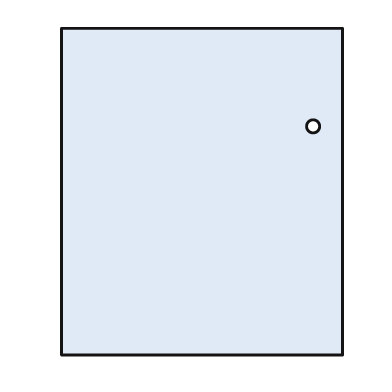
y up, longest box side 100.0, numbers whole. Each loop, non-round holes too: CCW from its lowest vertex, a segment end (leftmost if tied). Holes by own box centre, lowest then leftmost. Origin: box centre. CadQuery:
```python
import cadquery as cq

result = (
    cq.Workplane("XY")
    .moveTo(-43.0, -50.0)
    .lineTo(43.0, -50.0)
    .lineTo(43.0, 50.0)
    .lineTo(-43.0, 50.0)
    .close()
    .moveTo(34.0, 20.0)
    .circle(2.0)
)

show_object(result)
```